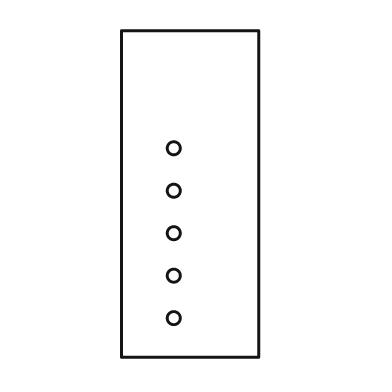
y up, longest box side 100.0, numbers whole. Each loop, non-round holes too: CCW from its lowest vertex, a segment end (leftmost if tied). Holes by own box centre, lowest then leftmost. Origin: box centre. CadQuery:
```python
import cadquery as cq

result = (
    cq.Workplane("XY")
    .moveTo(-21.0, -50.0)
    .lineTo(21.0, -50.0)
    .lineTo(21.0, 50.0)
    .lineTo(-21.0, 50.0)
    .close()
    .moveTo(-5.0, -38.0)
    .circle(2.0)
    .moveTo(-5.0, -25.0)
    .circle(2.0)
    .moveTo(-5.0, -12.0)
    .circle(2.0)
    .moveTo(-5.0, 1.0)
    .circle(2.0)
    .moveTo(-5.0, 14.0)
    .circle(2.0)
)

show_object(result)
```